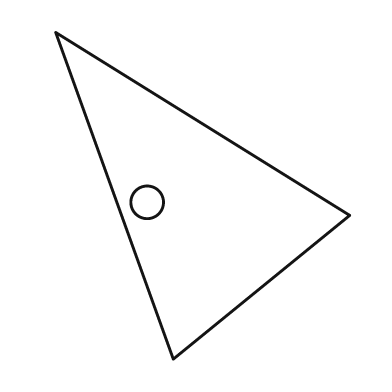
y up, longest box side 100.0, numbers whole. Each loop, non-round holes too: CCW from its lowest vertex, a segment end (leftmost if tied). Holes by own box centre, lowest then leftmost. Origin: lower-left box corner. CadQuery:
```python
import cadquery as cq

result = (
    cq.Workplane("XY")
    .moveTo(36.0, 0.0)
    .lineTo(90.0, 44.0)
    .lineTo(0.0, 100.0)
    .close()
    .moveTo(28.0, 48.0)
    .circle(5.0)
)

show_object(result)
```